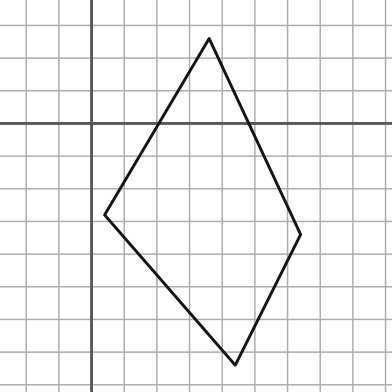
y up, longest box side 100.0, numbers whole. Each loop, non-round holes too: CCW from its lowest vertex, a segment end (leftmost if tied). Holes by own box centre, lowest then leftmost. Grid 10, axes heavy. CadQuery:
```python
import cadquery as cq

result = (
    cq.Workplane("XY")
    .moveTo(44.0, -74.0)
    .lineTo(64.0, -34.0)
    .lineTo(36.0, 26.0)
    .lineTo(4.0, -28.0)
    .close()
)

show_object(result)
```